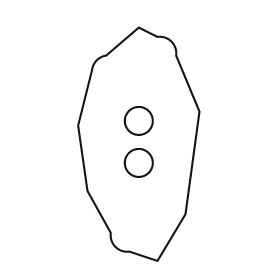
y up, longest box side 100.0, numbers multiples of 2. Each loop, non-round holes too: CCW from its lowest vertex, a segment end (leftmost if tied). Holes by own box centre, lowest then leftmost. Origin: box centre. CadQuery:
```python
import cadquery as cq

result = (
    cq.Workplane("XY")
    .moveTo(8.0, -50.0)
    .lineTo(20.0, -30.0)
    .lineTo(26.0, 14.0)
    .lineTo(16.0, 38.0)
    .threePointArc((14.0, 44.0), (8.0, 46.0))
    .lineTo(0.0, 50.0)
    .lineTo(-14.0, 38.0)
    .threePointArc((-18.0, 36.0), (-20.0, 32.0))
    .lineTo(-26.0, 8.0)
    .lineTo(-22.0, -20.0)
    .lineTo(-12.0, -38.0)
    .threePointArc((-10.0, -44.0), (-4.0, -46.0))
    .close()
    .moveTo(0.0, -8.0)
    .circle(6.0)
    .moveTo(0.0, 10.0)
    .circle(6.0)
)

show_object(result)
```